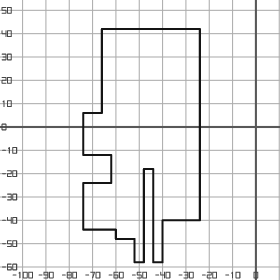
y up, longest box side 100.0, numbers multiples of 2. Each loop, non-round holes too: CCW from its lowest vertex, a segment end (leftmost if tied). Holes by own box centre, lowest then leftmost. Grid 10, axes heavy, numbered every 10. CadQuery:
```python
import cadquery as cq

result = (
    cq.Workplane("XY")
    .moveTo(-52.0, -58.0)
    .lineTo(-48.0, -58.0)
    .lineTo(-48.0, -18.0)
    .lineTo(-44.0, -18.0)
    .lineTo(-44.0, -58.0)
    .lineTo(-40.0, -58.0)
    .lineTo(-40.0, -40.0)
    .lineTo(-24.0, -40.0)
    .lineTo(-24.0, 42.0)
    .lineTo(-66.0, 42.0)
    .lineTo(-66.0, 6.0)
    .lineTo(-74.0, 6.0)
    .lineTo(-74.0, -12.0)
    .lineTo(-62.0, -12.0)
    .lineTo(-62.0, -24.0)
    .lineTo(-74.0, -24.0)
    .lineTo(-74.0, -44.0)
    .lineTo(-60.0, -44.0)
    .lineTo(-60.0, -48.0)
    .lineTo(-52.0, -48.0)
    .close()
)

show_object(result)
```